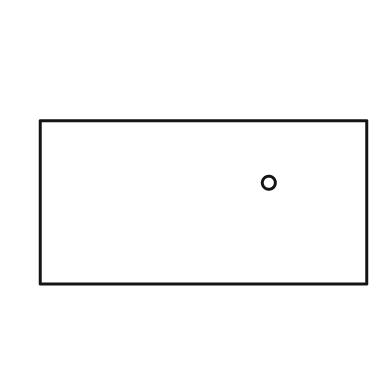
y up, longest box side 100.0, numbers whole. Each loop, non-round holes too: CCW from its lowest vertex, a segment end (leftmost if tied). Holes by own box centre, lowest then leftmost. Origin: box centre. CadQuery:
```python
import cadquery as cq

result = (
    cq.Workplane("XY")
    .moveTo(-50.0, -25.0)
    .lineTo(50.0, -25.0)
    .lineTo(50.0, 25.0)
    .lineTo(-50.0, 25.0)
    .close()
    .moveTo(20.0, 6.0)
    .circle(2.0)
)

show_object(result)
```